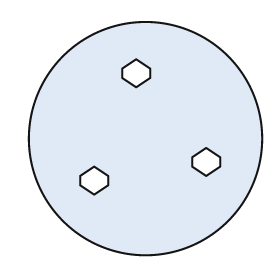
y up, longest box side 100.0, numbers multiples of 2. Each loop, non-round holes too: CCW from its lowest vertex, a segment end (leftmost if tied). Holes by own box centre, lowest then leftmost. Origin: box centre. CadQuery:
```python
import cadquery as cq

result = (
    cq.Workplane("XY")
    .moveTo(0.0, 0.0)
    .circle(50.0)
    .moveTo(-22.0, -24.0)
    .lineTo(-16.0, -20.0)
    .lineTo(-16.0, -16.0)
    .lineTo(-22.0, -12.0)
    .lineTo(-28.0, -16.0)
    .lineTo(-28.0, -20.0)
    .close()
    .moveTo(26.0, -16.0)
    .lineTo(32.0, -12.0)
    .lineTo(32.0, -8.0)
    .lineTo(26.0, -4.0)
    .lineTo(20.0, -8.0)
    .lineTo(20.0, -12.0)
    .close()
    .moveTo(-4.0, 22.0)
    .lineTo(2.0, 26.0)
    .lineTo(2.0, 30.0)
    .lineTo(-4.0, 34.0)
    .lineTo(-10.0, 30.0)
    .lineTo(-10.0, 26.0)
    .close()
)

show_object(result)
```